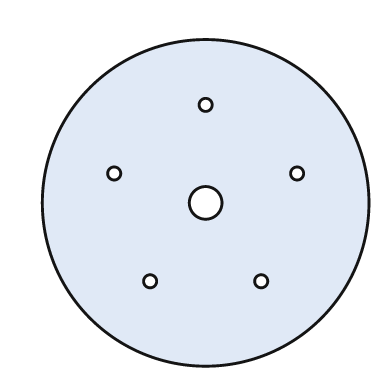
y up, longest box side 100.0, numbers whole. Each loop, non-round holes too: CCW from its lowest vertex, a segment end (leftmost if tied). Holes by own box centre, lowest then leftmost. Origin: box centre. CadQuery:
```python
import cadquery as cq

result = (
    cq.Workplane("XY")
    .moveTo(0.0, 0.0)
    .circle(50.0)
    .moveTo(-17.0, -24.0)
    .circle(2.0)
    .moveTo(17.0, -24.0)
    .circle(2.0)
    .moveTo(0.0, 0.0)
    .circle(5.0)
    .moveTo(-28.0, 9.0)
    .circle(2.0)
    .moveTo(28.0, 9.0)
    .circle(2.0)
    .moveTo(0.0, 30.0)
    .circle(2.0)
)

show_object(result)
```